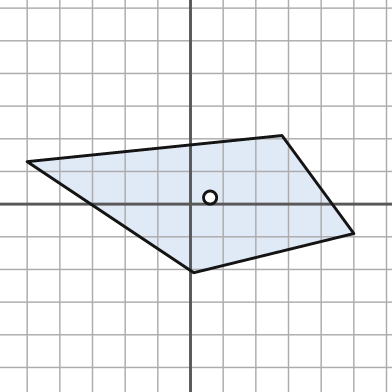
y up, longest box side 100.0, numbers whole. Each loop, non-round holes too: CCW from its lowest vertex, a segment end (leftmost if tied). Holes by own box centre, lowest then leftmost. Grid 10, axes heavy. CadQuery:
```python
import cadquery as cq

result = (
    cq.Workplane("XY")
    .moveTo(1.0, -21.0)
    .lineTo(50.0, -9.0)
    .lineTo(28.0, 21.0)
    .lineTo(-50.0, 13.0)
    .close()
    .moveTo(6.0, 2.0)
    .circle(2.0)
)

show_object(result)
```